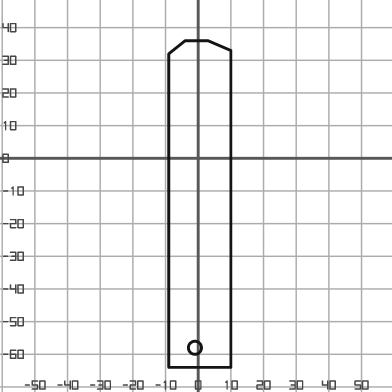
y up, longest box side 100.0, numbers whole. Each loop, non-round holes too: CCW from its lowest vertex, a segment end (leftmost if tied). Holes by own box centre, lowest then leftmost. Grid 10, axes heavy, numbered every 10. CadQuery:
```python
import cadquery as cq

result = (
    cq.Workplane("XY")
    .moveTo(-9.0, -64.0)
    .lineTo(10.0, -64.0)
    .lineTo(10.0, 33.0)
    .lineTo(3.0, 36.0)
    .lineTo(-4.0, 36.0)
    .lineTo(-9.0, 32.0)
    .close()
    .moveTo(-1.0, -58.0)
    .circle(2.0)
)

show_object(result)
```